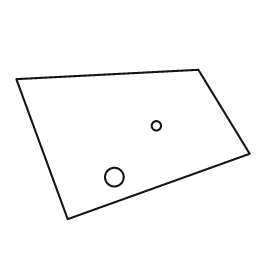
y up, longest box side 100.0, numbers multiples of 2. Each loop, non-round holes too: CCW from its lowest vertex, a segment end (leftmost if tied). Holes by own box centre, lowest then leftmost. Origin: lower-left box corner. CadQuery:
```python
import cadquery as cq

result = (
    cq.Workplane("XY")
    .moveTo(22.0, 0.0)
    .lineTo(100.0, 28.0)
    .lineTo(78.0, 64.0)
    .lineTo(0.0, 60.0)
    .close()
    .moveTo(42.0, 18.0)
    .circle(4.0)
    .moveTo(60.0, 40.0)
    .circle(2.0)
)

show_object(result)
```